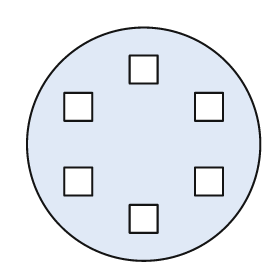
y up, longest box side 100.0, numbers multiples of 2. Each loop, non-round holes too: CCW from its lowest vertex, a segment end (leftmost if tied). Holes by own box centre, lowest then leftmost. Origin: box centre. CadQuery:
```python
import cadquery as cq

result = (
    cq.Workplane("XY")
    .moveTo(0.0, 0.0)
    .circle(50.0)
    .moveTo(-6.0, -38.0)
    .lineTo(6.0, -38.0)
    .lineTo(6.0, -26.0)
    .lineTo(-6.0, -26.0)
    .close()
    .moveTo(-34.0, -22.0)
    .lineTo(-22.0, -22.0)
    .lineTo(-22.0, -10.0)
    .lineTo(-34.0, -10.0)
    .close()
    .moveTo(22.0, -22.0)
    .lineTo(34.0, -22.0)
    .lineTo(34.0, -10.0)
    .lineTo(22.0, -10.0)
    .close()
    .moveTo(-34.0, 10.0)
    .lineTo(-22.0, 10.0)
    .lineTo(-22.0, 22.0)
    .lineTo(-34.0, 22.0)
    .close()
    .moveTo(22.0, 10.0)
    .lineTo(34.0, 10.0)
    .lineTo(34.0, 22.0)
    .lineTo(22.0, 22.0)
    .close()
    .moveTo(-6.0, 26.0)
    .lineTo(6.0, 26.0)
    .lineTo(6.0, 38.0)
    .lineTo(-6.0, 38.0)
    .close()
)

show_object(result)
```